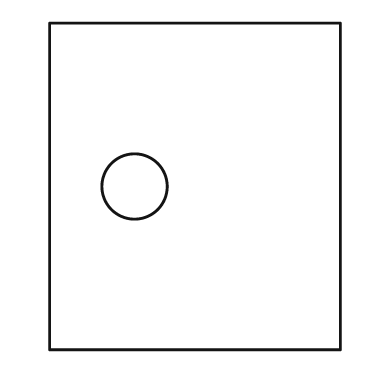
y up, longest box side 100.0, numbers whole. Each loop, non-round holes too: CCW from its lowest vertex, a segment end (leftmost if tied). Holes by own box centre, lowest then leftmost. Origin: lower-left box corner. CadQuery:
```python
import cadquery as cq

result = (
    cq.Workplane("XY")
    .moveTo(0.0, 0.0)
    .lineTo(89.0, 0.0)
    .lineTo(89.0, 100.0)
    .lineTo(0.0, 100.0)
    .close()
    .moveTo(26.0, 50.0)
    .circle(10.0)
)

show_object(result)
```